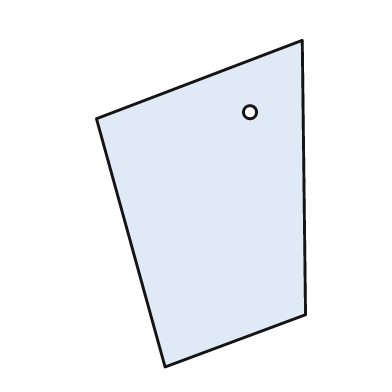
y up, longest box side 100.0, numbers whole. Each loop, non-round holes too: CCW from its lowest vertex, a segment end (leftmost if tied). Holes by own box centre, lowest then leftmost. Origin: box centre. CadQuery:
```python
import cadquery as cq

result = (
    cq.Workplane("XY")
    .moveTo(-11.0, -50.0)
    .lineTo(32.0, -34.0)
    .lineTo(31.0, 50.0)
    .lineTo(-32.0, 26.0)
    .close()
    .moveTo(15.0, 28.0)
    .circle(2.0)
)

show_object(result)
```